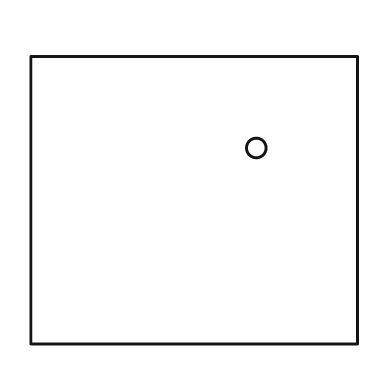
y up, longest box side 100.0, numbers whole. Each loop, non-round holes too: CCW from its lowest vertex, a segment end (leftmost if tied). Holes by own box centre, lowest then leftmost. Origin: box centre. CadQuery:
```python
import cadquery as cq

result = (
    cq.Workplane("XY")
    .moveTo(-50.0, -44.0)
    .lineTo(50.0, -44.0)
    .lineTo(50.0, 44.0)
    .lineTo(-50.0, 44.0)
    .close()
    .moveTo(19.0, 16.0)
    .circle(3.0)
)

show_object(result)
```